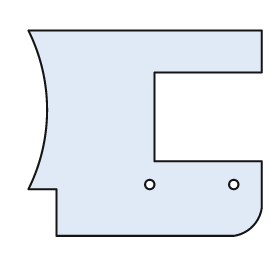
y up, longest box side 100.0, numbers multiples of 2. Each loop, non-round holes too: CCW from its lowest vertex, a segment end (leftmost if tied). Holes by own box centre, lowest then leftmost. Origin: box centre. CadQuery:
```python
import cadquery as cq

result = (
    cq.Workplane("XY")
    .moveTo(-38.0, -44.0)
    .lineTo(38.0, -44.0)
    .threePointArc((46.0, -40.0), (50.0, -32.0))
    .lineTo(50.0, -12.0)
    .lineTo(4.0, -12.0)
    .lineTo(4.0, 26.0)
    .lineTo(50.0, 26.0)
    .lineTo(50.0, 44.0)
    .lineTo(-50.0, 44.0)
    .threePointArc((-42.0, 10.0), (-50.0, -24.0))
    .lineTo(-38.0, -24.0)
    .close()
    .moveTo(2.0, -22.0)
    .circle(2.0)
    .moveTo(38.0, -22.0)
    .circle(2.0)
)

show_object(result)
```